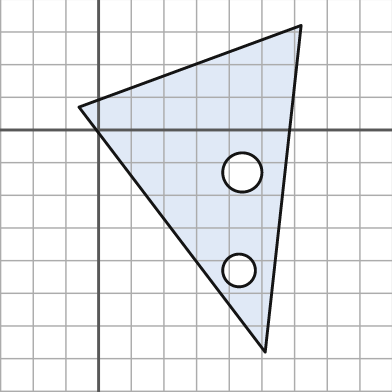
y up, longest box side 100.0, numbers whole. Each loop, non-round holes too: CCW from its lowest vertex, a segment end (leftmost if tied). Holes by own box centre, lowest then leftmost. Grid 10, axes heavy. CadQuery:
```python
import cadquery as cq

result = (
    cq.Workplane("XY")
    .moveTo(51.0, -68.0)
    .lineTo(62.0, 32.0)
    .lineTo(-6.0, 7.0)
    .close()
    .moveTo(43.0, -43.0)
    .circle(5.0)
    .moveTo(44.0, -13.0)
    .circle(6.0)
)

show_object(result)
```